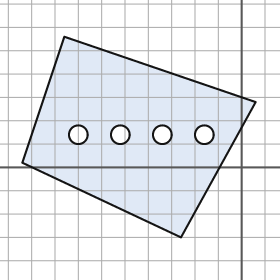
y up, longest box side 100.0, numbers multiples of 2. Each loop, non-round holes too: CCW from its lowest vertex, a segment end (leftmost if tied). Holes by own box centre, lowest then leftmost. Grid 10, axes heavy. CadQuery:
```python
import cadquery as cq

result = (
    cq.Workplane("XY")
    .moveTo(-26.0, -30.0)
    .lineTo(6.0, 28.0)
    .lineTo(-76.0, 56.0)
    .lineTo(-94.0, 2.0)
    .close()
    .moveTo(-70.0, 14.0)
    .circle(4.0)
    .moveTo(-52.0, 14.0)
    .circle(4.0)
    .moveTo(-34.0, 14.0)
    .circle(4.0)
    .moveTo(-16.0, 14.0)
    .circle(4.0)
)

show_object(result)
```